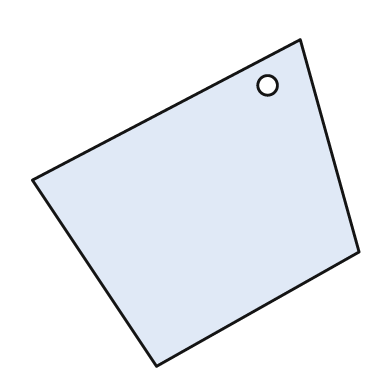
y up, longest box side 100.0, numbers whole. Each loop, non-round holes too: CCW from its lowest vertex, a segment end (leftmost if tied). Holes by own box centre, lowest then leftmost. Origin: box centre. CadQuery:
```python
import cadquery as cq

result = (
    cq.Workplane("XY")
    .moveTo(-12.0, -50.0)
    .lineTo(50.0, -15.0)
    .lineTo(32.0, 50.0)
    .lineTo(-50.0, 7.0)
    .close()
    .moveTo(22.0, 36.0)
    .circle(3.0)
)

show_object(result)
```